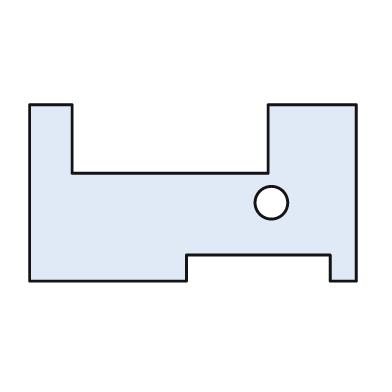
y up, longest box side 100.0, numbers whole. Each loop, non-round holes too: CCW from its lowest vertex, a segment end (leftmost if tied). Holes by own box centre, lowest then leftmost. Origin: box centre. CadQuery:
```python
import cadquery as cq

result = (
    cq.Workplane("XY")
    .moveTo(-50.0, -27.0)
    .lineTo(-2.0, -27.0)
    .lineTo(-2.0, -19.0)
    .lineTo(42.0, -19.0)
    .lineTo(42.0, -27.0)
    .lineTo(50.0, -27.0)
    .lineTo(50.0, 27.0)
    .lineTo(23.0, 27.0)
    .lineTo(23.0, 6.0)
    .lineTo(-37.0, 6.0)
    .lineTo(-37.0, 27.0)
    .lineTo(-50.0, 27.0)
    .close()
    .moveTo(24.0, -3.0)
    .circle(5.0)
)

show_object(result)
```